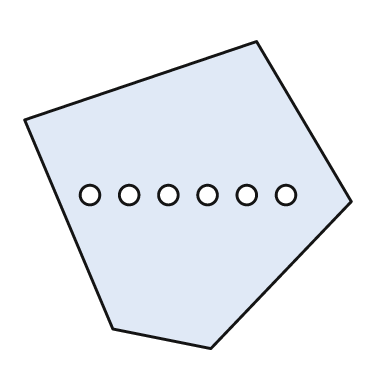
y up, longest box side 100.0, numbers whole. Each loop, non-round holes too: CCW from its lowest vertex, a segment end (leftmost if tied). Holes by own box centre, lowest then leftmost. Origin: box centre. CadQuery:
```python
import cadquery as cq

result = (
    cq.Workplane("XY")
    .moveTo(7.0, -47.0)
    .lineTo(50.0, -2.0)
    .lineTo(21.0, 47.0)
    .lineTo(-50.0, 23.0)
    .lineTo(-23.0, -41.0)
    .close()
    .moveTo(-30.0, 0.0)
    .circle(3.0)
    .moveTo(-18.0, 0.0)
    .circle(3.0)
    .moveTo(-6.0, 0.0)
    .circle(3.0)
    .moveTo(6.0, 0.0)
    .circle(3.0)
    .moveTo(18.0, 0.0)
    .circle(3.0)
    .moveTo(30.0, 0.0)
    .circle(3.0)
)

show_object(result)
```